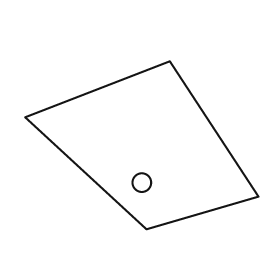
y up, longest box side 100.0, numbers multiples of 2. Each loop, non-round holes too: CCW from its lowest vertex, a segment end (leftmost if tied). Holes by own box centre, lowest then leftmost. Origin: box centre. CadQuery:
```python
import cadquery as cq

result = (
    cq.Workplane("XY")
    .moveTo(2.0, -36.0)
    .lineTo(50.0, -22.0)
    .lineTo(12.0, 36.0)
    .lineTo(-50.0, 12.0)
    .close()
    .moveTo(0.0, -16.0)
    .circle(4.0)
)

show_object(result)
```